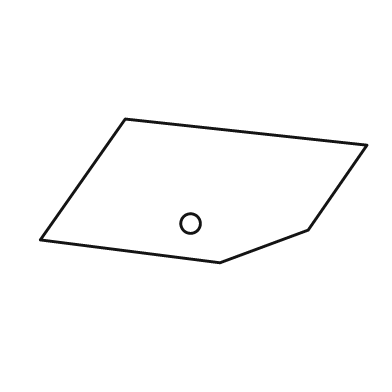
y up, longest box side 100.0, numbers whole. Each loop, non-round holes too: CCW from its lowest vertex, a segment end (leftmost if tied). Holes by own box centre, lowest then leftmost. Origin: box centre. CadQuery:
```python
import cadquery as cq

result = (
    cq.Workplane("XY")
    .moveTo(5.0, -22.0)
    .lineTo(32.0, -12.0)
    .lineTo(50.0, 14.0)
    .lineTo(-24.0, 22.0)
    .lineTo(-50.0, -15.0)
    .close()
    .moveTo(-4.0, -10.0)
    .circle(3.0)
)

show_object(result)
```